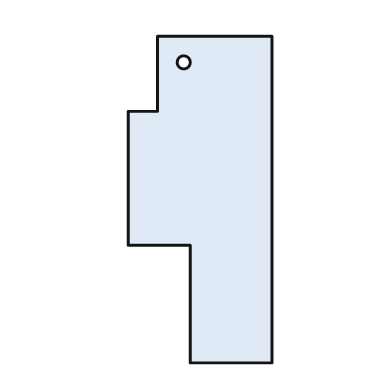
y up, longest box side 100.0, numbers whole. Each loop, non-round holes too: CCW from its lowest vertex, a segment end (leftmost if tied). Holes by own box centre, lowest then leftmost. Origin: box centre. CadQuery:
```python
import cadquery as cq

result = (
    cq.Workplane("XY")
    .moveTo(-3.0, -50.0)
    .lineTo(22.0, -50.0)
    .lineTo(22.0, 50.0)
    .lineTo(-13.0, 50.0)
    .lineTo(-13.0, 27.0)
    .lineTo(-22.0, 27.0)
    .lineTo(-22.0, -14.0)
    .lineTo(-3.0, -14.0)
    .close()
    .moveTo(-5.0, 42.0)
    .circle(2.0)
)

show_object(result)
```